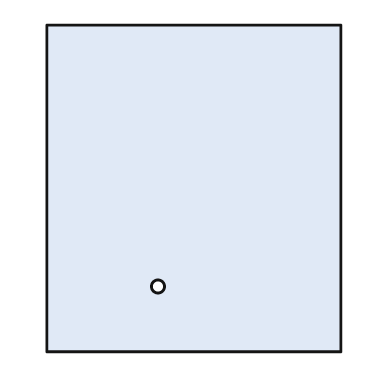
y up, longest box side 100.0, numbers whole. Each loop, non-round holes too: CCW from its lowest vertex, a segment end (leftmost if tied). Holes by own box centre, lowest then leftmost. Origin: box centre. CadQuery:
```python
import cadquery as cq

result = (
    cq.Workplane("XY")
    .moveTo(-45.0, -50.0)
    .lineTo(45.0, -50.0)
    .lineTo(45.0, 50.0)
    .lineTo(-45.0, 50.0)
    .close()
    .moveTo(-11.0, -30.0)
    .circle(2.0)
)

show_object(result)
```